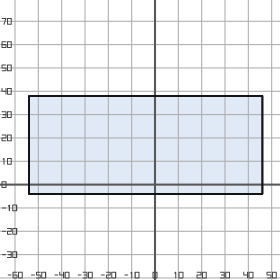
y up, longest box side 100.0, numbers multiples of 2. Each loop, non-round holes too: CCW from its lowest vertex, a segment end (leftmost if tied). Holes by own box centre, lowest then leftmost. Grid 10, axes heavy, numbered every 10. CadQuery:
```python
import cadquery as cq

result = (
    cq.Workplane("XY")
    .moveTo(-54.0, -4.0)
    .lineTo(46.0, -4.0)
    .lineTo(46.0, 38.0)
    .lineTo(-54.0, 38.0)
    .close()
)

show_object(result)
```